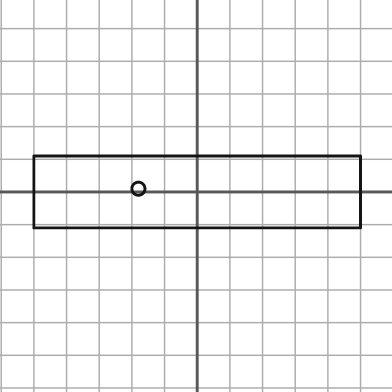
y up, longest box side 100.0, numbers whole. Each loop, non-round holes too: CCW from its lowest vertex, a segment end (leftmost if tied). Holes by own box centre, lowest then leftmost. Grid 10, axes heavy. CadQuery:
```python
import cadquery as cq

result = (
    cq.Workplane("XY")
    .moveTo(-50.0, -11.0)
    .lineTo(50.0, -11.0)
    .lineTo(50.0, 11.0)
    .lineTo(-50.0, 11.0)
    .close()
    .moveTo(-18.0, 1.0)
    .circle(2.0)
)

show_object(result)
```